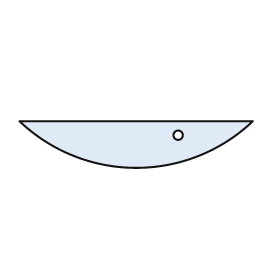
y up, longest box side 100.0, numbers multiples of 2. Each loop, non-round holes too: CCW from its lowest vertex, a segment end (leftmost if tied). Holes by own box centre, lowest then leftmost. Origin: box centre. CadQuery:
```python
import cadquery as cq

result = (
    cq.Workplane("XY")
    .moveTo(-50.0, 10.0)
    .threePointArc((0.0, -10.0), (50.0, 10.0))
    .close()
    .moveTo(18.0, 4.0)
    .circle(2.0)
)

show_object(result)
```